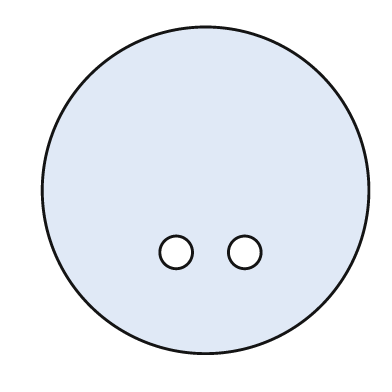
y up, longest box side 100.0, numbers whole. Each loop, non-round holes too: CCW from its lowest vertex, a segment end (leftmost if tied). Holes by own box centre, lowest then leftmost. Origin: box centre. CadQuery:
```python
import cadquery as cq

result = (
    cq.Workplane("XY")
    .moveTo(0.0, 0.0)
    .circle(50.0)
    .moveTo(-9.0, -19.0)
    .circle(5.0)
    .moveTo(12.0, -19.0)
    .circle(5.0)
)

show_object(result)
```